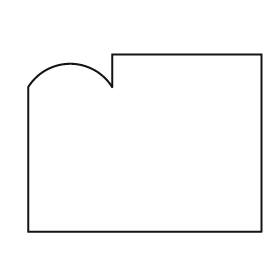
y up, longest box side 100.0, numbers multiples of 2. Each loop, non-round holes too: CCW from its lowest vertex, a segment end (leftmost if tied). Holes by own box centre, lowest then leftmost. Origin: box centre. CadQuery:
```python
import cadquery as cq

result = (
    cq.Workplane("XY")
    .moveTo(-50.0, -38.0)
    .lineTo(50.0, -38.0)
    .lineTo(50.0, 38.0)
    .lineTo(-14.0, 38.0)
    .lineTo(-14.0, 24.0)
    .threePointArc((-32.0, 34.0), (-50.0, 24.0))
    .close()
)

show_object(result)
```